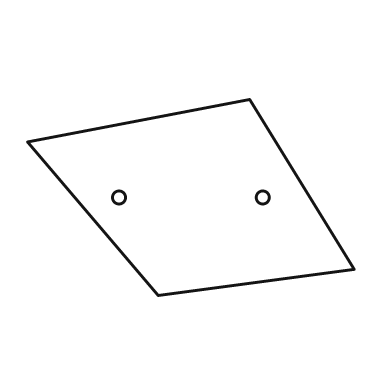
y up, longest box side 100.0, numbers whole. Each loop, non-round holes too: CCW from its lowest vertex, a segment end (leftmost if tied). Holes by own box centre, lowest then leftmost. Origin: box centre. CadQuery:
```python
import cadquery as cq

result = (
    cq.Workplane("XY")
    .moveTo(-10.0, -30.0)
    .lineTo(50.0, -22.0)
    .lineTo(18.0, 30.0)
    .lineTo(-50.0, 17.0)
    .close()
    .moveTo(-22.0, 0.0)
    .circle(2.0)
    .moveTo(22.0, 0.0)
    .circle(2.0)
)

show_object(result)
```